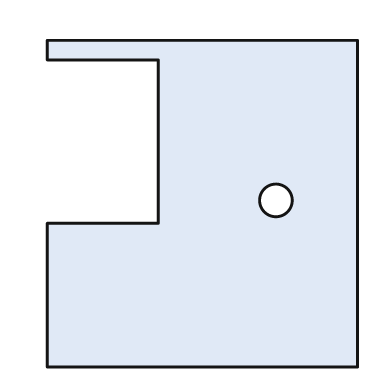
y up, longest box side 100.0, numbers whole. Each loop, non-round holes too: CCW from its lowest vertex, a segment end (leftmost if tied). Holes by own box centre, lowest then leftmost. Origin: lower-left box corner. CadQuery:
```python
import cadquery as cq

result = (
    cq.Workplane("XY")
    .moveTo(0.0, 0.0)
    .lineTo(95.0, 0.0)
    .lineTo(95.0, 100.0)
    .lineTo(0.0, 100.0)
    .lineTo(0.0, 94.0)
    .lineTo(34.0, 94.0)
    .lineTo(34.0, 44.0)
    .lineTo(0.0, 44.0)
    .close()
    .moveTo(70.0, 51.0)
    .circle(5.0)
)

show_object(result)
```